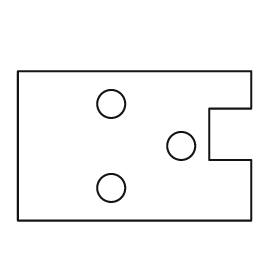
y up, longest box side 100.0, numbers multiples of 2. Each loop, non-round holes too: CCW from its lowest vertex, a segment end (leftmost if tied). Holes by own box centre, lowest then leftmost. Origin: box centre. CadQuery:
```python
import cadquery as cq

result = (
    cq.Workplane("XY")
    .moveTo(-50.0, -32.0)
    .lineTo(50.0, -32.0)
    .lineTo(50.0, -6.0)
    .lineTo(32.0, -6.0)
    .lineTo(32.0, 16.0)
    .lineTo(50.0, 16.0)
    .lineTo(50.0, 32.0)
    .lineTo(-50.0, 32.0)
    .close()
    .moveTo(-10.0, -18.0)
    .circle(6.0)
    .moveTo(20.0, 0.0)
    .circle(6.0)
    .moveTo(-10.0, 18.0)
    .circle(6.0)
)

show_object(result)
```